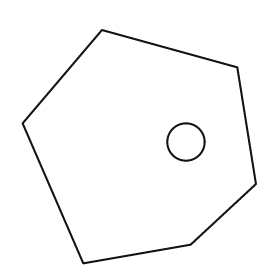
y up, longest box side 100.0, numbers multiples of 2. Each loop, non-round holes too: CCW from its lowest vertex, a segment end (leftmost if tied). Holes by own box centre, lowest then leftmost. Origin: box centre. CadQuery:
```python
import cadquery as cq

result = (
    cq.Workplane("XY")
    .moveTo(-24.0, -50.0)
    .lineTo(22.0, -42.0)
    .lineTo(50.0, -16.0)
    .lineTo(42.0, 34.0)
    .lineTo(-16.0, 50.0)
    .lineTo(-50.0, 10.0)
    .close()
    .moveTo(20.0, 2.0)
    .circle(8.0)
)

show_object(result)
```